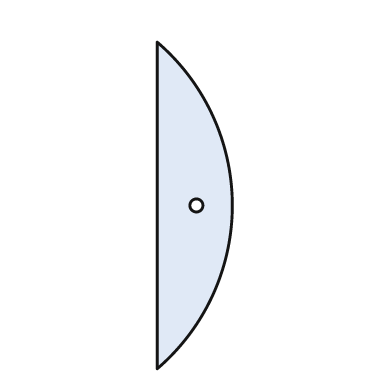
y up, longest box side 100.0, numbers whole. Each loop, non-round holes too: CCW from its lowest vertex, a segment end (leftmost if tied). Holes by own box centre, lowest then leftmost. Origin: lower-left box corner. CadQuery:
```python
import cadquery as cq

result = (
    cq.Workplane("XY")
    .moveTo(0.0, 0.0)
    .threePointArc((23.0, 50.0), (0.0, 100.0))
    .close()
    .moveTo(12.0, 50.0)
    .circle(2.0)
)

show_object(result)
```